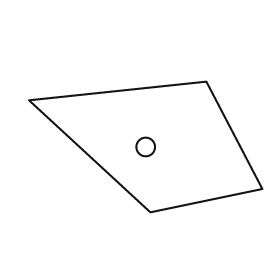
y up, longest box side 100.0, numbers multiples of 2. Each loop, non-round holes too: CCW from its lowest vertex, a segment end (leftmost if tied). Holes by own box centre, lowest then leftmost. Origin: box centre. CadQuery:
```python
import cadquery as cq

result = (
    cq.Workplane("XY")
    .moveTo(2.0, -28.0)
    .lineTo(50.0, -18.0)
    .lineTo(26.0, 28.0)
    .lineTo(-50.0, 20.0)
    .close()
    .moveTo(0.0, 0.0)
    .circle(4.0)
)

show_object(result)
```